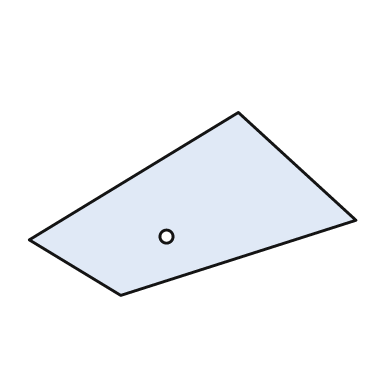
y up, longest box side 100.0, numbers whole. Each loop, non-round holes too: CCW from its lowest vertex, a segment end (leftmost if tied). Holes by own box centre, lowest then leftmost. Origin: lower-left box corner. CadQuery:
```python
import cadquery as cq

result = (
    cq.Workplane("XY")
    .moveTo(28.0, 0.0)
    .lineTo(100.0, 23.0)
    .lineTo(64.0, 56.0)
    .lineTo(0.0, 17.0)
    .close()
    .moveTo(42.0, 18.0)
    .circle(2.0)
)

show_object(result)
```